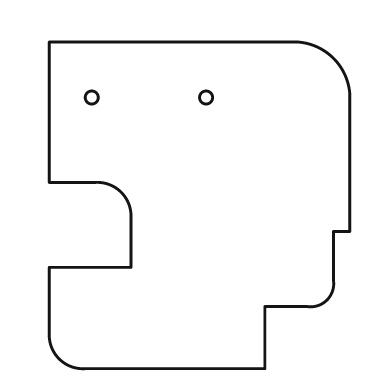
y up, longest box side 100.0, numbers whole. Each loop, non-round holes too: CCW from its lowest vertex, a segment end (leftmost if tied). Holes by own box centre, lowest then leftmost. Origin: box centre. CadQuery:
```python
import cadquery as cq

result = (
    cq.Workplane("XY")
    .moveTo(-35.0, -50.0)
    .lineTo(20.0, -50.0)
    .lineTo(20.0, -31.0)
    .lineTo(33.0, -31.0)
    .threePointArc((39.0, -29.0), (41.0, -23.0))
    .lineTo(41.0, -8.0)
    .lineTo(46.0, -8.0)
    .lineTo(46.0, 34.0)
    .threePointArc((41.0, 45.0), (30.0, 50.0))
    .lineTo(-46.0, 50.0)
    .lineTo(-46.0, 7.0)
    .lineTo(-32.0, 7.0)
    .threePointArc((-24.0, 4.0), (-21.0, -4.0))
    .lineTo(-21.0, -19.0)
    .lineTo(-46.0, -19.0)
    .lineTo(-46.0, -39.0)
    .threePointArc((-43.0, -47.0), (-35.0, -50.0))
    .close()
    .moveTo(-33.0, 33.0)
    .circle(2.0)
    .moveTo(2.0, 33.0)
    .circle(2.0)
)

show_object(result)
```